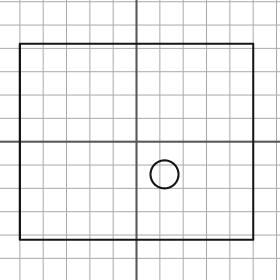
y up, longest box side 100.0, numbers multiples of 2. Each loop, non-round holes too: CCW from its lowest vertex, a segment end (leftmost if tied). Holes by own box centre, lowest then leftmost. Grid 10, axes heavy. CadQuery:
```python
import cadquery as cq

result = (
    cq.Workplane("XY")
    .moveTo(-50.0, -42.0)
    .lineTo(50.0, -42.0)
    .lineTo(50.0, 42.0)
    .lineTo(-50.0, 42.0)
    .close()
    .moveTo(12.0, -14.0)
    .circle(6.0)
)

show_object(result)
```